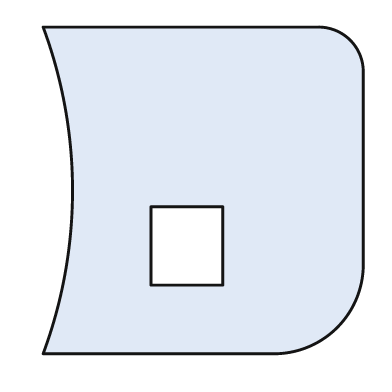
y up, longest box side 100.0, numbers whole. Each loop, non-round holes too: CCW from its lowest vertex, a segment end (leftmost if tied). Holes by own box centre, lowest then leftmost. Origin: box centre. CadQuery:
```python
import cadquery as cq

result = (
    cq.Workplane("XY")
    .moveTo(-49.0, -50.0)
    .lineTo(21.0, -50.0)
    .threePointArc((41.0, -42.0), (49.0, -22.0))
    .lineTo(49.0, 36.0)
    .threePointArc((45.0, 46.0), (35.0, 50.0))
    .lineTo(-49.0, 50.0)
    .threePointArc((-40.0, 0.0), (-49.0, -50.0))
    .close()
    .moveTo(-16.0, -29.0)
    .lineTo(6.0, -29.0)
    .lineTo(6.0, -5.0)
    .lineTo(-16.0, -5.0)
    .close()
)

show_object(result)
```